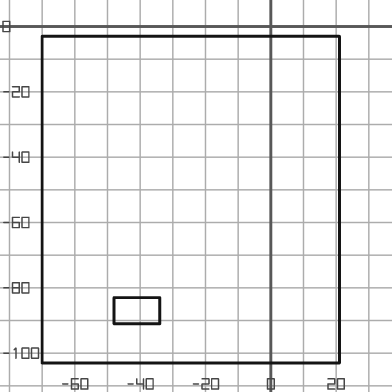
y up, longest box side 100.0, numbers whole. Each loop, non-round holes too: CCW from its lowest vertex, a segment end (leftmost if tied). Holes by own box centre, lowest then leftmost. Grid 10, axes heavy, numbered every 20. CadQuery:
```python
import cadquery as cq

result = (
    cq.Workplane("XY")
    .moveTo(-70.0, -103.0)
    .lineTo(21.0, -103.0)
    .lineTo(21.0, -3.0)
    .lineTo(-70.0, -3.0)
    .close()
    .moveTo(-48.0, -91.0)
    .lineTo(-34.0, -91.0)
    .lineTo(-34.0, -83.0)
    .lineTo(-48.0, -83.0)
    .close()
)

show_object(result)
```